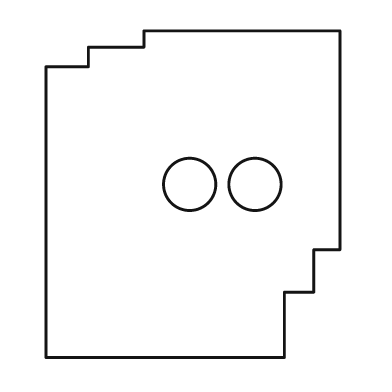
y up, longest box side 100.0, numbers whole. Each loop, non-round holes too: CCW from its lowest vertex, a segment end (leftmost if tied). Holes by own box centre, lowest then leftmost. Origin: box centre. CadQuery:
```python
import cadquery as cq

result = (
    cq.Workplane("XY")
    .moveTo(-45.0, -50.0)
    .lineTo(28.0, -50.0)
    .lineTo(28.0, -30.0)
    .lineTo(37.0, -30.0)
    .lineTo(37.0, -17.0)
    .lineTo(45.0, -17.0)
    .lineTo(45.0, 50.0)
    .lineTo(-15.0, 50.0)
    .lineTo(-15.0, 45.0)
    .lineTo(-32.0, 45.0)
    .lineTo(-32.0, 39.0)
    .lineTo(-45.0, 39.0)
    .close()
    .moveTo(-1.0, 3.0)
    .circle(8.0)
    .moveTo(19.0, 3.0)
    .circle(8.0)
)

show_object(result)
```